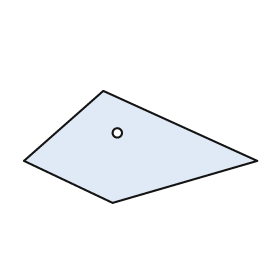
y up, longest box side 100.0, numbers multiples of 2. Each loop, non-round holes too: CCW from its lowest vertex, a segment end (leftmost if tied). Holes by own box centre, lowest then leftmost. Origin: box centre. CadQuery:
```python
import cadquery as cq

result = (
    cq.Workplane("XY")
    .moveTo(-12.0, -24.0)
    .lineTo(50.0, -6.0)
    .lineTo(-16.0, 24.0)
    .lineTo(-50.0, -6.0)
    .close()
    .moveTo(-10.0, 6.0)
    .circle(2.0)
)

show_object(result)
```